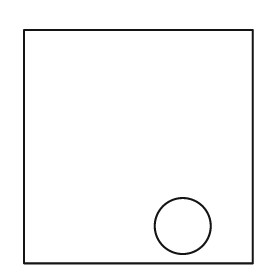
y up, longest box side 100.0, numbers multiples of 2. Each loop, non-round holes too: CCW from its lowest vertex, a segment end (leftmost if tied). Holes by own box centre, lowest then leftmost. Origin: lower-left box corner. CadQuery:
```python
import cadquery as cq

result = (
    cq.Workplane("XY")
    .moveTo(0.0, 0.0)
    .lineTo(98.0, 0.0)
    .lineTo(98.0, 100.0)
    .lineTo(0.0, 100.0)
    .close()
    .moveTo(68.0, 16.0)
    .circle(12.0)
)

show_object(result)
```